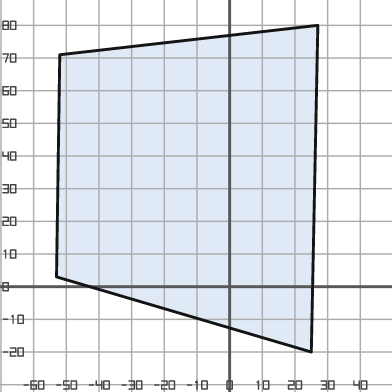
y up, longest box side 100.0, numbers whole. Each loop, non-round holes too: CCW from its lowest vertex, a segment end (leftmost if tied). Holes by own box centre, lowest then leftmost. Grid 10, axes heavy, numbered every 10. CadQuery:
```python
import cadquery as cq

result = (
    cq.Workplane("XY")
    .moveTo(25.0, -20.0)
    .lineTo(27.0, 80.0)
    .lineTo(-52.0, 71.0)
    .lineTo(-53.0, 3.0)
    .close()
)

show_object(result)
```